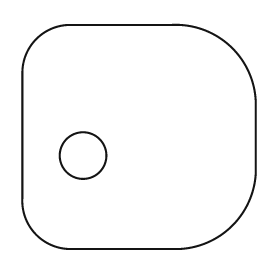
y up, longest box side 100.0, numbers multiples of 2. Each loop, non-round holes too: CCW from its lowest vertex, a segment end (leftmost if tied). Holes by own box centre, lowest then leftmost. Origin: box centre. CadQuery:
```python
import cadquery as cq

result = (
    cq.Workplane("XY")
    .moveTo(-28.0, -48.0)
    .lineTo(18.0, -48.0)
    .threePointArc((40.0, -38.0), (50.0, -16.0))
    .lineTo(50.0, 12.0)
    .threePointArc((40.0, 38.0), (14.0, 48.0))
    .lineTo(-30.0, 48.0)
    .threePointArc((-44.0, 42.0), (-50.0, 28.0))
    .lineTo(-50.0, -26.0)
    .threePointArc((-44.0, -42.0), (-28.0, -48.0))
    .close()
    .moveTo(-24.0, -8.0)
    .circle(10.0)
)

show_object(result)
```